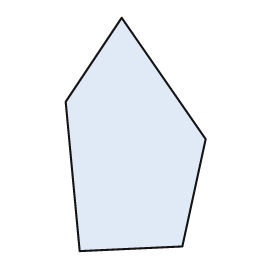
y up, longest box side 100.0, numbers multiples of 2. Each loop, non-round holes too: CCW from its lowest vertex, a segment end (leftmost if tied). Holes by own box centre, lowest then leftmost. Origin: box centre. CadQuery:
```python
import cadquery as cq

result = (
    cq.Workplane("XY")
    .moveTo(-24.0, -50.0)
    .lineTo(20.0, -48.0)
    .lineTo(30.0, -2.0)
    .lineTo(-6.0, 50.0)
    .lineTo(-30.0, 14.0)
    .close()
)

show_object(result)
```